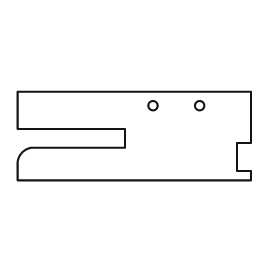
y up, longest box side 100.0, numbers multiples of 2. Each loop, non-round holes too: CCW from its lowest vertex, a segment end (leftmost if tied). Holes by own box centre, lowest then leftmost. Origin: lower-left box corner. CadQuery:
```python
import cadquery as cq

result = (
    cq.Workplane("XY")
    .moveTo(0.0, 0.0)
    .lineTo(100.0, 0.0)
    .lineTo(100.0, 4.0)
    .lineTo(94.0, 4.0)
    .lineTo(94.0, 16.0)
    .lineTo(100.0, 16.0)
    .lineTo(100.0, 38.0)
    .lineTo(0.0, 38.0)
    .lineTo(0.0, 22.0)
    .lineTo(46.0, 22.0)
    .lineTo(46.0, 14.0)
    .lineTo(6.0, 14.0)
    .threePointArc((2.0, 12.0), (0.0, 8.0))
    .close()
    .moveTo(58.0, 32.0)
    .circle(2.0)
    .moveTo(78.0, 32.0)
    .circle(2.0)
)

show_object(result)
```